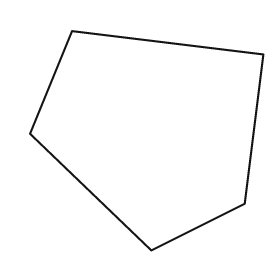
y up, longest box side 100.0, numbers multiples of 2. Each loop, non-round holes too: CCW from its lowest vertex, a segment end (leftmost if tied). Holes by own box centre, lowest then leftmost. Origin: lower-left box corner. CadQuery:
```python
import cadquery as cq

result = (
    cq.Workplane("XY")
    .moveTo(52.0, 0.0)
    .lineTo(92.0, 20.0)
    .lineTo(100.0, 84.0)
    .lineTo(18.0, 94.0)
    .lineTo(0.0, 50.0)
    .close()
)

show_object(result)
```